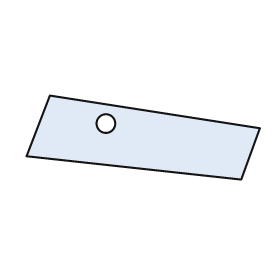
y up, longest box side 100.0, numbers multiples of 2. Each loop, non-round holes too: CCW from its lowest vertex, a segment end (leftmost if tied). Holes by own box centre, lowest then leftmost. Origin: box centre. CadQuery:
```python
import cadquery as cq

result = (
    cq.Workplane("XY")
    .moveTo(42.0, -18.0)
    .lineTo(50.0, 4.0)
    .lineTo(-40.0, 18.0)
    .lineTo(-50.0, -8.0)
    .close()
    .moveTo(-16.0, 6.0)
    .circle(4.0)
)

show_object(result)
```